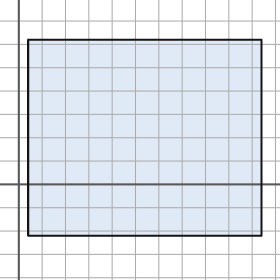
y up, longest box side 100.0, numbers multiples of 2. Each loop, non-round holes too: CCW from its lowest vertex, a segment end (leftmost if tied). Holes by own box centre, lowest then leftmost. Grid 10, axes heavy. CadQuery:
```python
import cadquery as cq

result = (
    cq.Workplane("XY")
    .moveTo(4.0, -22.0)
    .lineTo(104.0, -22.0)
    .lineTo(104.0, 62.0)
    .lineTo(4.0, 62.0)
    .close()
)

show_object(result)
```